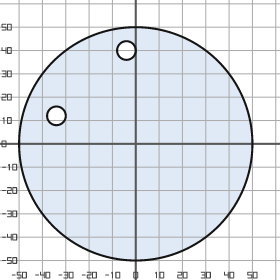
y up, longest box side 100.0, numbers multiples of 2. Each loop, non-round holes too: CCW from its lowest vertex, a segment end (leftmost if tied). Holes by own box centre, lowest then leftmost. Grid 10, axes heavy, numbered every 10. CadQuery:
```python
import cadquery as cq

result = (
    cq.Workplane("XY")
    .moveTo(0.0, 0.0)
    .circle(50.0)
    .moveTo(-34.0, 12.0)
    .circle(4.0)
    .moveTo(-4.0, 40.0)
    .circle(4.0)
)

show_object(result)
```